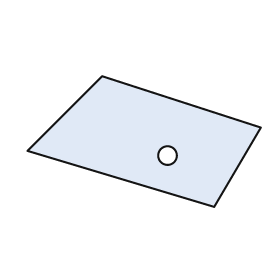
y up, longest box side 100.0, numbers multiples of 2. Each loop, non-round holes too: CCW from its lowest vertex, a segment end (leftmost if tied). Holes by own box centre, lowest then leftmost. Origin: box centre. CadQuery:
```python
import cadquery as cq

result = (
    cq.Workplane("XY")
    .moveTo(30.0, -28.0)
    .lineTo(50.0, 6.0)
    .lineTo(-18.0, 28.0)
    .lineTo(-50.0, -4.0)
    .close()
    .moveTo(10.0, -6.0)
    .circle(4.0)
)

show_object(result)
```